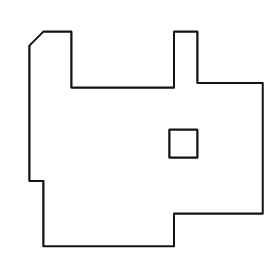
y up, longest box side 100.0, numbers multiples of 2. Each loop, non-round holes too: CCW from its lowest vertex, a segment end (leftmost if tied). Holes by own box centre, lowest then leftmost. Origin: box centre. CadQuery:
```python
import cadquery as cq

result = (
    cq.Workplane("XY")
    .moveTo(-44.0, -46.0)
    .lineTo(12.0, -46.0)
    .lineTo(12.0, -32.0)
    .lineTo(50.0, -32.0)
    .lineTo(50.0, 24.0)
    .lineTo(22.0, 24.0)
    .lineTo(22.0, 46.0)
    .lineTo(12.0, 46.0)
    .lineTo(12.0, 22.0)
    .lineTo(-32.0, 22.0)
    .lineTo(-32.0, 46.0)
    .lineTo(-44.0, 46.0)
    .lineTo(-50.0, 40.0)
    .lineTo(-50.0, -18.0)
    .lineTo(-44.0, -18.0)
    .close()
    .moveTo(10.0, -8.0)
    .lineTo(22.0, -8.0)
    .lineTo(22.0, 4.0)
    .lineTo(10.0, 4.0)
    .close()
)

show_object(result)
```